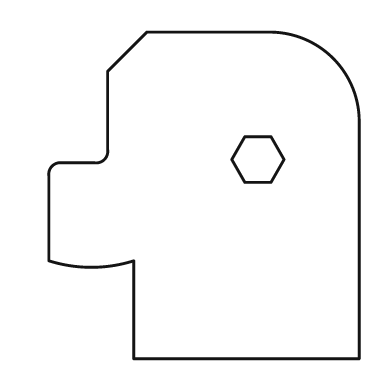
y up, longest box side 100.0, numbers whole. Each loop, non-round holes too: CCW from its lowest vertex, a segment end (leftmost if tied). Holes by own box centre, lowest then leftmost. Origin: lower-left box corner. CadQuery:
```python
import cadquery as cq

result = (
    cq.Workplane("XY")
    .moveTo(26.0, 0.0)
    .lineTo(95.0, 0.0)
    .lineTo(95.0, 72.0)
    .threePointArc((87.0, 92.0), (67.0, 100.0))
    .lineTo(30.0, 100.0)
    .lineTo(18.0, 88.0)
    .lineTo(18.0, 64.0)
    .threePointArc((17.0, 61.0), (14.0, 60.0))
    .lineTo(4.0, 60.0)
    .threePointArc((1.0, 59.0), (0.0, 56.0))
    .lineTo(0.0, 30.0)
    .threePointArc((13.0, 28.0), (26.0, 30.0))
    .close()
    .moveTo(60.0, 54.0)
    .lineTo(68.0, 54.0)
    .lineTo(72.0, 61.0)
    .lineTo(68.0, 68.0)
    .lineTo(60.0, 68.0)
    .lineTo(56.0, 61.0)
    .close()
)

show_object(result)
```